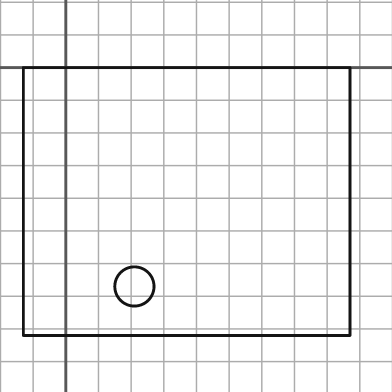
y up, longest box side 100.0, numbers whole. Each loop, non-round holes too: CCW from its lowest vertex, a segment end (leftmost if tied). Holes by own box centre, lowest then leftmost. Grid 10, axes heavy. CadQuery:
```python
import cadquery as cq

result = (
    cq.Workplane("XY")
    .moveTo(-13.0, -82.0)
    .lineTo(87.0, -82.0)
    .lineTo(87.0, 0.0)
    .lineTo(-13.0, 0.0)
    .close()
    .moveTo(21.0, -67.0)
    .circle(6.0)
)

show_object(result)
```